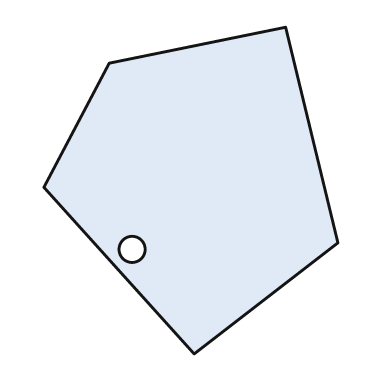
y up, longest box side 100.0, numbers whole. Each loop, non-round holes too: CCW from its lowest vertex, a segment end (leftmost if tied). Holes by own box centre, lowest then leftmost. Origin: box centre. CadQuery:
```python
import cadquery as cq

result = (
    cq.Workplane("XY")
    .moveTo(1.0, -50.0)
    .lineTo(45.0, -16.0)
    .lineTo(29.0, 50.0)
    .lineTo(-25.0, 39.0)
    .lineTo(-45.0, 1.0)
    .close()
    .moveTo(-18.0, -18.0)
    .circle(4.0)
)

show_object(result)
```